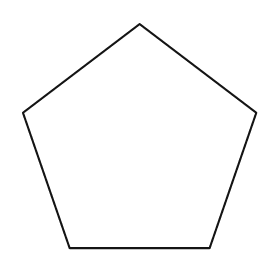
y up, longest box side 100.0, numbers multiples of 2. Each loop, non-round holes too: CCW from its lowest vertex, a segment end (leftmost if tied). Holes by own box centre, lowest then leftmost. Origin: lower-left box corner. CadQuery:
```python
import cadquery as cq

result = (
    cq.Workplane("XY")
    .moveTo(20.0, 0.0)
    .lineTo(80.0, 0.0)
    .lineTo(100.0, 58.0)
    .lineTo(50.0, 96.0)
    .lineTo(0.0, 58.0)
    .close()
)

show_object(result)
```